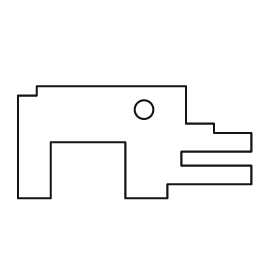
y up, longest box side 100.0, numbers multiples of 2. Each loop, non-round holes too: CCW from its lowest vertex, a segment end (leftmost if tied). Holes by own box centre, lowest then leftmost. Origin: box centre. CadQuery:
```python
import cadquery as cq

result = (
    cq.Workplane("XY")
    .moveTo(-50.0, -24.0)
    .lineTo(-36.0, -24.0)
    .lineTo(-36.0, 0.0)
    .lineTo(-4.0, 0.0)
    .lineTo(-4.0, -24.0)
    .lineTo(14.0, -24.0)
    .lineTo(14.0, -18.0)
    .lineTo(50.0, -18.0)
    .lineTo(50.0, -10.0)
    .lineTo(20.0, -10.0)
    .lineTo(20.0, -4.0)
    .lineTo(50.0, -4.0)
    .lineTo(50.0, 4.0)
    .lineTo(34.0, 4.0)
    .lineTo(34.0, 8.0)
    .lineTo(22.0, 8.0)
    .lineTo(22.0, 24.0)
    .lineTo(-42.0, 24.0)
    .lineTo(-42.0, 20.0)
    .lineTo(-50.0, 20.0)
    .close()
    .moveTo(4.0, 14.0)
    .circle(4.0)
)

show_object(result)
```